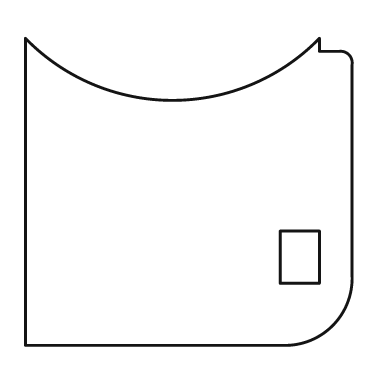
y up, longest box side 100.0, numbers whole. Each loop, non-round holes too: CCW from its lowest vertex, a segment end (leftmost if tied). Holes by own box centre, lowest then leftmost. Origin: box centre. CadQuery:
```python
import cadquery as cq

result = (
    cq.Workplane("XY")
    .moveTo(-50.0, -47.0)
    .lineTo(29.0, -47.0)
    .threePointArc((44.0, -41.0), (50.0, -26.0))
    .lineTo(50.0, 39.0)
    .threePointArc((49.0, 42.0), (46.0, 43.0))
    .lineTo(40.0, 43.0)
    .lineTo(40.0, 47.0)
    .threePointArc((-5.0, 28.0), (-50.0, 47.0))
    .close()
    .moveTo(28.0, -28.0)
    .lineTo(40.0, -28.0)
    .lineTo(40.0, -12.0)
    .lineTo(28.0, -12.0)
    .close()
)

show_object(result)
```